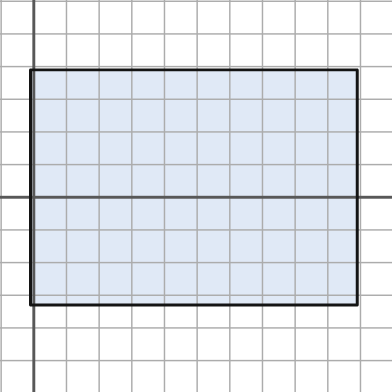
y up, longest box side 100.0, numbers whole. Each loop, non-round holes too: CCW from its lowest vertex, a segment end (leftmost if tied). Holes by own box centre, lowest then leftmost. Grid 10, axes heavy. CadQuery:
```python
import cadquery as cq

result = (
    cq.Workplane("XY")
    .moveTo(-1.0, -33.0)
    .lineTo(99.0, -33.0)
    .lineTo(99.0, 39.0)
    .lineTo(-1.0, 39.0)
    .close()
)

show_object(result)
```